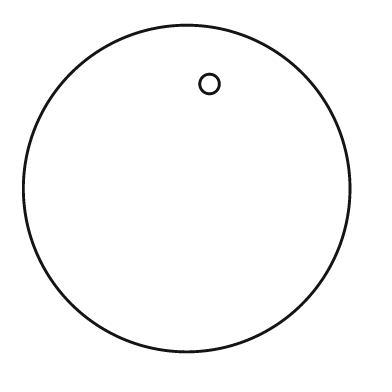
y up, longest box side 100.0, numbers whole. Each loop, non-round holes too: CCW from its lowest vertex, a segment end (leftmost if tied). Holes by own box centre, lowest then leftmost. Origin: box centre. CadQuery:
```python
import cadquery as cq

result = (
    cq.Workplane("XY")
    .moveTo(0.0, 0.0)
    .circle(50.0)
    .moveTo(7.0, 32.0)
    .circle(3.0)
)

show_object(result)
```